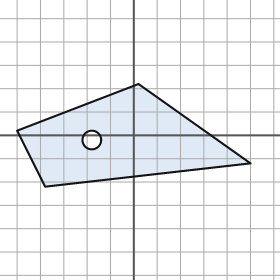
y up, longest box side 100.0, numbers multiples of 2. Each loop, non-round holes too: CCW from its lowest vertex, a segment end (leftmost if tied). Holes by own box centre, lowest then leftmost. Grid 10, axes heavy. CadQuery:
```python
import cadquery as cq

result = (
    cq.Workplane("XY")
    .moveTo(-38.0, -22.0)
    .lineTo(50.0, -12.0)
    .lineTo(2.0, 22.0)
    .lineTo(-50.0, 2.0)
    .close()
    .moveTo(-18.0, -2.0)
    .circle(4.0)
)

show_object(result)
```